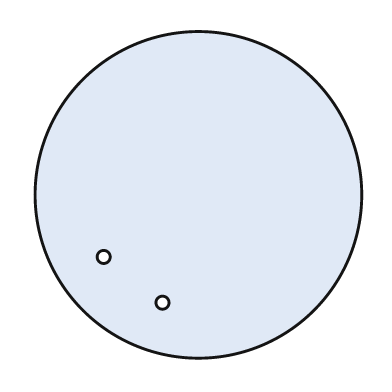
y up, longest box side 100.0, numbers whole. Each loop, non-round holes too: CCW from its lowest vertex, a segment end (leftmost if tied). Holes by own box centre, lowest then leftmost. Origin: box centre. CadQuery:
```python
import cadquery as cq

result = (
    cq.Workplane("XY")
    .moveTo(0.0, 0.0)
    .circle(50.0)
    .moveTo(-11.0, -33.0)
    .circle(2.0)
    .moveTo(-29.0, -19.0)
    .circle(2.0)
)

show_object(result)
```